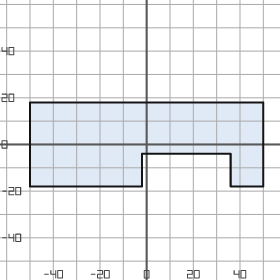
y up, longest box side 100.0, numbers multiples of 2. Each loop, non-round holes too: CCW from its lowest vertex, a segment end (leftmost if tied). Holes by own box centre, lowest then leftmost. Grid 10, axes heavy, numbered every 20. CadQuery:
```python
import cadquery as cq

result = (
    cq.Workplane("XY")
    .moveTo(-50.0, -18.0)
    .lineTo(-2.0, -18.0)
    .lineTo(-2.0, -4.0)
    .lineTo(36.0, -4.0)
    .lineTo(36.0, -18.0)
    .lineTo(50.0, -18.0)
    .lineTo(50.0, 18.0)
    .lineTo(-50.0, 18.0)
    .close()
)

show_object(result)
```